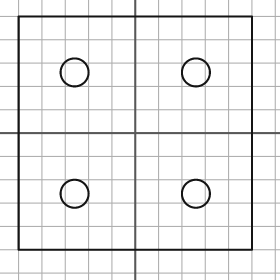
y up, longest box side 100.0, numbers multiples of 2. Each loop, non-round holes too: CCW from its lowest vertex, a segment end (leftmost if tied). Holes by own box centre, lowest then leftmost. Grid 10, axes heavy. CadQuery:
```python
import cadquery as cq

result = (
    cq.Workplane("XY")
    .moveTo(-50.0, -50.0)
    .lineTo(50.0, -50.0)
    .lineTo(50.0, 50.0)
    .lineTo(-50.0, 50.0)
    .close()
    .moveTo(-26.0, -26.0)
    .circle(6.0)
    .moveTo(26.0, -26.0)
    .circle(6.0)
    .moveTo(-26.0, 26.0)
    .circle(6.0)
    .moveTo(26.0, 26.0)
    .circle(6.0)
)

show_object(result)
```